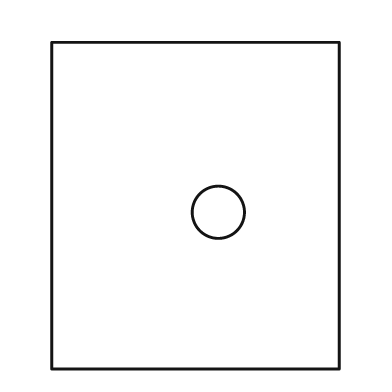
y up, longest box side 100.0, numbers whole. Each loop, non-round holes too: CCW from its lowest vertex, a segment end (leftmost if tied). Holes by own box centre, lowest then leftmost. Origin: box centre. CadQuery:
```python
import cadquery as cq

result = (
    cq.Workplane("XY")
    .moveTo(-44.0, -50.0)
    .lineTo(44.0, -50.0)
    .lineTo(44.0, 50.0)
    .lineTo(-44.0, 50.0)
    .close()
    .moveTo(7.0, -2.0)
    .circle(8.0)
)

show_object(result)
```